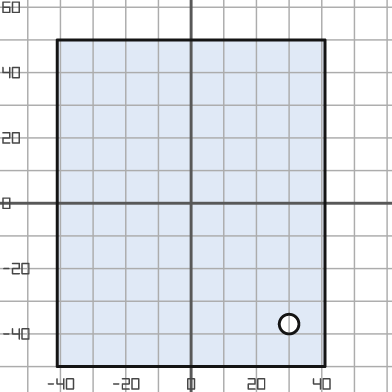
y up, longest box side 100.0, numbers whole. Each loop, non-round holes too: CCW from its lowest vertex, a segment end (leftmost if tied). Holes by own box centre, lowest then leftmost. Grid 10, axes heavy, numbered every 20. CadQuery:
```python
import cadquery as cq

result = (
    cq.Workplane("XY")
    .moveTo(-41.0, -50.0)
    .lineTo(41.0, -50.0)
    .lineTo(41.0, 50.0)
    .lineTo(-41.0, 50.0)
    .close()
    .moveTo(30.0, -37.0)
    .circle(3.0)
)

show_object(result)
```